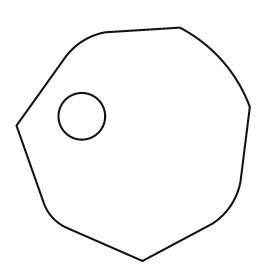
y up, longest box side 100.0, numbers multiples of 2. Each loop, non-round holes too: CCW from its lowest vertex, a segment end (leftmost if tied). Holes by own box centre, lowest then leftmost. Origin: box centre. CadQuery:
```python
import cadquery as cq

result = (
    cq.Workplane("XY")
    .moveTo(4.0, -50.0)
    .lineTo(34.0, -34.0)
    .threePointArc((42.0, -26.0), (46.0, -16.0))
    .lineTo(50.0, 16.0)
    .threePointArc((38.0, 36.0), (20.0, 50.0))
    .lineTo(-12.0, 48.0)
    .threePointArc((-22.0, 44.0), (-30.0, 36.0))
    .lineTo(-50.0, 8.0)
    .lineTo(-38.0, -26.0)
    .threePointArc((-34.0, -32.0), (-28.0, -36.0))
    .close()
    .moveTo(-22.0, 12.0)
    .circle(10.0)
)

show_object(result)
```